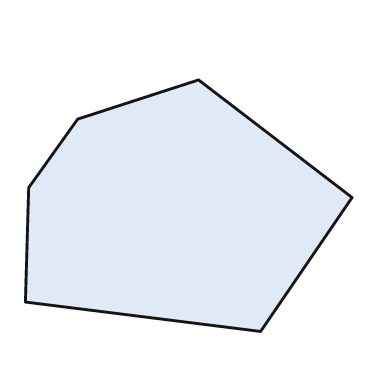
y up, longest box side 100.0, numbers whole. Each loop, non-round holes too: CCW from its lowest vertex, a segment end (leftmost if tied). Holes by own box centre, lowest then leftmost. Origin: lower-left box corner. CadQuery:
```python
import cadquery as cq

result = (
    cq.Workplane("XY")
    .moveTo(72.0, 0.0)
    .lineTo(100.0, 41.0)
    .lineTo(53.0, 77.0)
    .lineTo(16.0, 65.0)
    .lineTo(1.0, 44.0)
    .lineTo(0.0, 9.0)
    .close()
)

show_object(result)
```